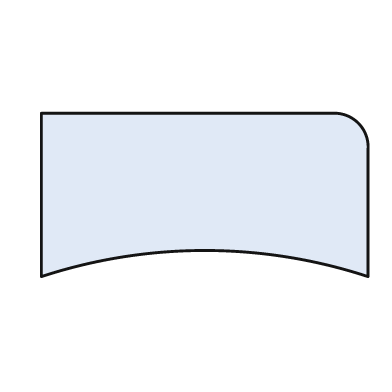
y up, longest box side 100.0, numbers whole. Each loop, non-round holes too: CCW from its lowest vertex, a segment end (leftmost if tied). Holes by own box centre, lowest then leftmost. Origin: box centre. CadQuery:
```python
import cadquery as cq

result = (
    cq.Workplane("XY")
    .moveTo(-50.0, -25.0)
    .threePointArc((0.0, -17.0), (50.0, -25.0))
    .lineTo(50.0, 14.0)
    .threePointArc((47.0, 22.0), (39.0, 25.0))
    .lineTo(-50.0, 25.0)
    .close()
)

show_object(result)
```